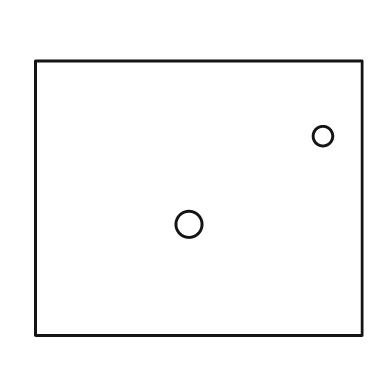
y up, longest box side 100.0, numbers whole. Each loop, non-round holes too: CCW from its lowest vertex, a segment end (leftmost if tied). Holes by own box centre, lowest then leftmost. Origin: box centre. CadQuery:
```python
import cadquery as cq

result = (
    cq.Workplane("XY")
    .moveTo(-50.0, -42.0)
    .lineTo(50.0, -42.0)
    .lineTo(50.0, 42.0)
    .lineTo(-50.0, 42.0)
    .close()
    .moveTo(-3.0, -8.0)
    .circle(4.0)
    .moveTo(38.0, 19.0)
    .circle(3.0)
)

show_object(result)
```